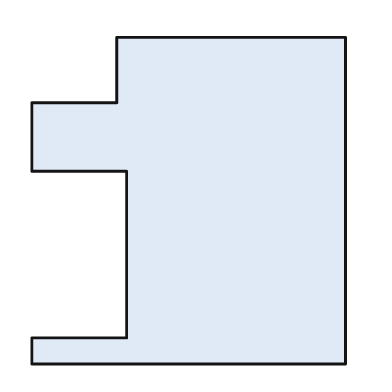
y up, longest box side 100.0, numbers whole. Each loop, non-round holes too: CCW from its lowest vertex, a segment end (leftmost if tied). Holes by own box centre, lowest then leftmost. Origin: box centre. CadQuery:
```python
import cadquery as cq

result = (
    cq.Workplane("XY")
    .moveTo(-48.0, -50.0)
    .lineTo(48.0, -50.0)
    .lineTo(48.0, 50.0)
    .lineTo(-22.0, 50.0)
    .lineTo(-22.0, 30.0)
    .lineTo(-48.0, 30.0)
    .lineTo(-48.0, 9.0)
    .lineTo(-19.0, 9.0)
    .lineTo(-19.0, -42.0)
    .lineTo(-48.0, -42.0)
    .close()
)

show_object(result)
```